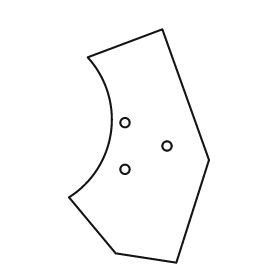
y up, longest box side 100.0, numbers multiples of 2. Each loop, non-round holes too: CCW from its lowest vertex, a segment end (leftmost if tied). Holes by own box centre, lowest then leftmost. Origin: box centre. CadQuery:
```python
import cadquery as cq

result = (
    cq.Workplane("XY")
    .moveTo(16.0, -50.0)
    .lineTo(30.0, -6.0)
    .lineTo(10.0, 50.0)
    .lineTo(-22.0, 38.0)
    .threePointArc((-12.0, 6.0), (-30.0, -22.0))
    .lineTo(-10.0, -46.0)
    .close()
    .moveTo(-6.0, -10.0)
    .circle(2.0)
    .moveTo(12.0, 0.0)
    .circle(2.0)
    .moveTo(-6.0, 10.0)
    .circle(2.0)
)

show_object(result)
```